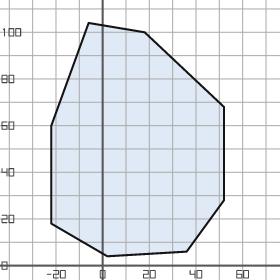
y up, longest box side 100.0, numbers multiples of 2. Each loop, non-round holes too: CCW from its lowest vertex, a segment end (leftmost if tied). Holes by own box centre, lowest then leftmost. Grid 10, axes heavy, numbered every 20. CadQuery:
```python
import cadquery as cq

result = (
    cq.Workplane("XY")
    .moveTo(2.0, 4.0)
    .lineTo(36.0, 6.0)
    .lineTo(52.0, 28.0)
    .lineTo(52.0, 68.0)
    .lineTo(18.0, 100.0)
    .lineTo(-6.0, 104.0)
    .lineTo(-22.0, 60.0)
    .lineTo(-22.0, 18.0)
    .close()
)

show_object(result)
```